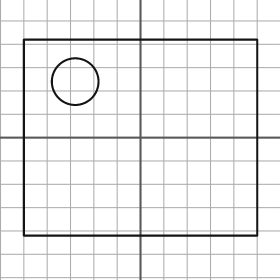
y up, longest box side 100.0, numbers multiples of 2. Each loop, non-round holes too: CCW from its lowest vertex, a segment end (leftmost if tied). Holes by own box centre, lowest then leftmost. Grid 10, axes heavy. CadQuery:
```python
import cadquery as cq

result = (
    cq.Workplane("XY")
    .moveTo(-50.0, -42.0)
    .lineTo(50.0, -42.0)
    .lineTo(50.0, 42.0)
    .lineTo(-50.0, 42.0)
    .close()
    .moveTo(-28.0, 24.0)
    .circle(10.0)
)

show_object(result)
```